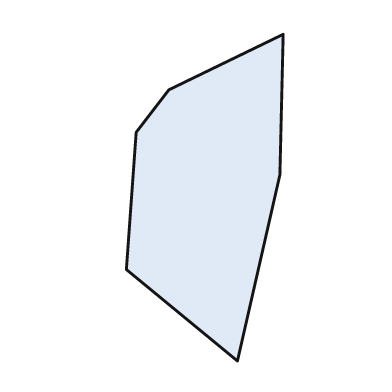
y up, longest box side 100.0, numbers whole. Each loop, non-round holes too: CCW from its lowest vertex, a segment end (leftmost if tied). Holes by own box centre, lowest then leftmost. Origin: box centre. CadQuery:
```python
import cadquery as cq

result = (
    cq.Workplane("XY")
    .moveTo(10.0, -50.0)
    .lineTo(23.0, 7.0)
    .lineTo(24.0, 50.0)
    .lineTo(-11.0, 33.0)
    .lineTo(-21.0, 20.0)
    .lineTo(-24.0, -22.0)
    .close()
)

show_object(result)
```